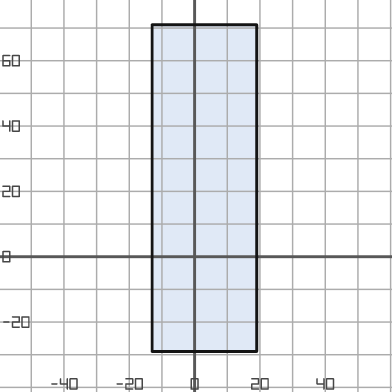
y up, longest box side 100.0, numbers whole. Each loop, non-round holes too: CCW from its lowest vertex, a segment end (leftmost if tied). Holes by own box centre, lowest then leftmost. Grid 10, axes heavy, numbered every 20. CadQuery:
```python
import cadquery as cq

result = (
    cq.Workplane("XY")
    .moveTo(-13.0, -29.0)
    .lineTo(19.0, -29.0)
    .lineTo(19.0, 71.0)
    .lineTo(-13.0, 71.0)
    .close()
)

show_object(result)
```